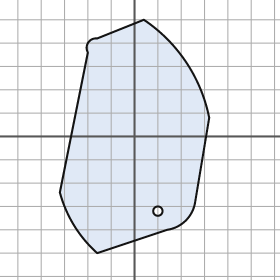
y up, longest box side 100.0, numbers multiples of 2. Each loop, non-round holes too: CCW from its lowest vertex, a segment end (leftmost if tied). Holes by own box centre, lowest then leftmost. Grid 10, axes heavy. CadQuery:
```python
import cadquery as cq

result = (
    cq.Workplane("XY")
    .moveTo(-16.0, -50.0)
    .lineTo(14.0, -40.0)
    .threePointArc((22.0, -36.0), (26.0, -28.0))
    .lineTo(32.0, 8.0)
    .threePointArc((22.0, 32.0), (4.0, 50.0))
    .lineTo(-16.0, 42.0)
    .threePointArc((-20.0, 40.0), (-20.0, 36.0))
    .lineTo(-32.0, -24.0)
    .threePointArc((-26.0, -38.0), (-16.0, -50.0))
    .close()
    .moveTo(10.0, -32.0)
    .circle(2.0)
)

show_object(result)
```